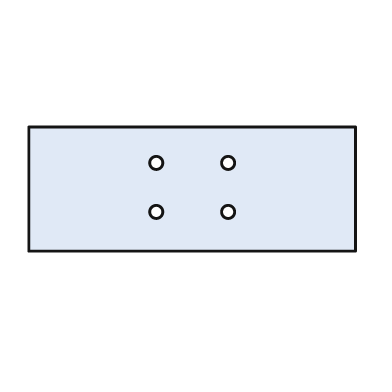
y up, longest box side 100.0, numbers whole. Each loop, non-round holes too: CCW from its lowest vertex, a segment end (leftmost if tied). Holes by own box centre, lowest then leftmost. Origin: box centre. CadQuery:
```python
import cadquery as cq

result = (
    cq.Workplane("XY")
    .moveTo(-50.0, -19.0)
    .lineTo(50.0, -19.0)
    .lineTo(50.0, 19.0)
    .lineTo(-50.0, 19.0)
    .close()
    .moveTo(-11.0, -7.0)
    .circle(2.0)
    .moveTo(11.0, -7.0)
    .circle(2.0)
    .moveTo(-11.0, 8.0)
    .circle(2.0)
    .moveTo(11.0, 8.0)
    .circle(2.0)
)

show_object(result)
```